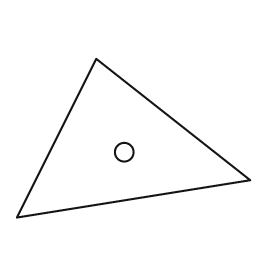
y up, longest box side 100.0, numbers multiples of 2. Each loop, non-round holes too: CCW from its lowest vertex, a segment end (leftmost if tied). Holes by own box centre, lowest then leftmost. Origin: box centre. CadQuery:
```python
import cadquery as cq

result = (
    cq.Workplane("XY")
    .moveTo(-50.0, -34.0)
    .lineTo(50.0, -18.0)
    .lineTo(-16.0, 34.0)
    .close()
    .moveTo(-4.0, -6.0)
    .circle(4.0)
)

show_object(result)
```